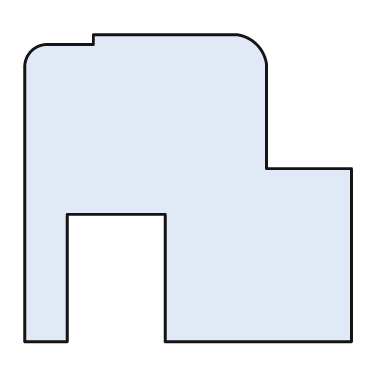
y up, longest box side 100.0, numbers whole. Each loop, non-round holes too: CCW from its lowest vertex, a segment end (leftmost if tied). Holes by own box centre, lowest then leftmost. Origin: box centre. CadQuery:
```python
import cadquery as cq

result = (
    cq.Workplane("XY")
    .moveTo(-50.0, -47.0)
    .lineTo(-37.0, -47.0)
    .lineTo(-37.0, -8.0)
    .lineTo(-7.0, -8.0)
    .lineTo(-7.0, -47.0)
    .lineTo(50.0, -47.0)
    .lineTo(50.0, 6.0)
    .lineTo(24.0, 6.0)
    .lineTo(24.0, 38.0)
    .threePointArc((21.0, 44.0), (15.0, 47.0))
    .lineTo(-29.0, 47.0)
    .lineTo(-29.0, 44.0)
    .lineTo(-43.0, 44.0)
    .threePointArc((-48.0, 42.0), (-50.0, 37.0))
    .close()
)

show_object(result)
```